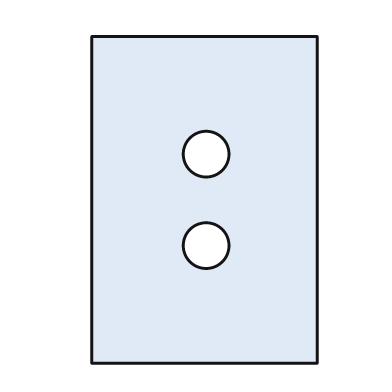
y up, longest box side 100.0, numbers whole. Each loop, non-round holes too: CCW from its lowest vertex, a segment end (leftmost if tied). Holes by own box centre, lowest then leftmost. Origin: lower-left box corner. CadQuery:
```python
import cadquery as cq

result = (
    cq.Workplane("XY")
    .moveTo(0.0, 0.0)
    .lineTo(69.0, 0.0)
    .lineTo(69.0, 100.0)
    .lineTo(0.0, 100.0)
    .close()
    .moveTo(35.0, 36.0)
    .circle(7.0)
    .moveTo(35.0, 64.0)
    .circle(7.0)
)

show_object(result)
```